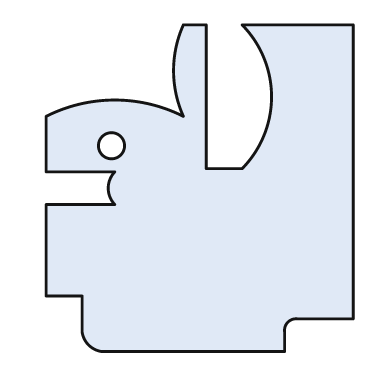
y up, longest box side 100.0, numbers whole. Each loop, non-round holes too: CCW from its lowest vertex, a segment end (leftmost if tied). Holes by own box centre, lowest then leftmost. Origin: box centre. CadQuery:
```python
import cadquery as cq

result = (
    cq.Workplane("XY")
    .moveTo(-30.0, -50.0)
    .lineTo(26.0, -50.0)
    .lineTo(26.0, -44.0)
    .threePointArc((27.0, -41.0), (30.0, -40.0))
    .lineTo(47.0, -40.0)
    .lineTo(47.0, 50.0)
    .lineTo(13.0, 50.0)
    .threePointArc((22.0, 28.0), (13.0, 6.0))
    .lineTo(2.0, 6.0)
    .lineTo(2.0, 50.0)
    .lineTo(-5.0, 50.0)
    .threePointArc((-8.0, 36.0), (-5.0, 22.0))
    .threePointArc((-26.0, 27.0), (-47.0, 22.0))
    .lineTo(-47.0, 5.0)
    .lineTo(-26.0, 5.0)
    .threePointArc((-28.0, 0.0), (-26.0, -5.0))
    .lineTo(-47.0, -5.0)
    .lineTo(-47.0, -33.0)
    .lineTo(-36.0, -33.0)
    .lineTo(-36.0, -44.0)
    .threePointArc((-34.0, -48.0), (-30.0, -50.0))
    .close()
    .moveTo(-27.0, 13.0)
    .circle(4.0)
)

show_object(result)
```